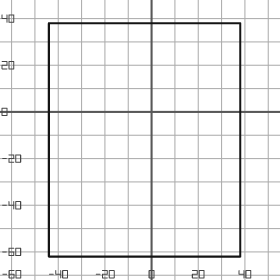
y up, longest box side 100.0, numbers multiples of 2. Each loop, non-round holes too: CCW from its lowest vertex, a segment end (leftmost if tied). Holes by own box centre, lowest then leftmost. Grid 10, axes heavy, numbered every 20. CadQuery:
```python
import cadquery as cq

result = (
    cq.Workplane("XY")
    .moveTo(-44.0, -62.0)
    .lineTo(38.0, -62.0)
    .lineTo(38.0, 38.0)
    .lineTo(-44.0, 38.0)
    .close()
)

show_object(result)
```